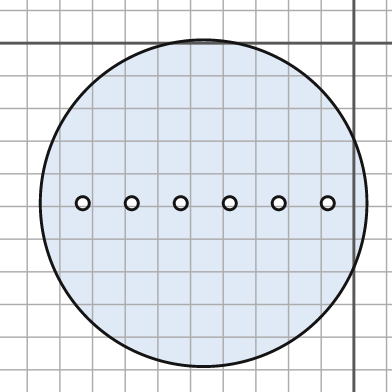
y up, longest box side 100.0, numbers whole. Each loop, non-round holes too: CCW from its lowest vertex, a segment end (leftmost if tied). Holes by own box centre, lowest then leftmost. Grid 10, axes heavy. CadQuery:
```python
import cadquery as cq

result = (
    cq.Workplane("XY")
    .moveTo(-46.0, -49.0)
    .circle(50.0)
    .moveTo(-83.0, -49.0)
    .circle(2.0)
    .moveTo(-68.0, -49.0)
    .circle(2.0)
    .moveTo(-53.0, -49.0)
    .circle(2.0)
    .moveTo(-38.0, -49.0)
    .circle(2.0)
    .moveTo(-23.0, -49.0)
    .circle(2.0)
    .moveTo(-8.0, -49.0)
    .circle(2.0)
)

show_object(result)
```